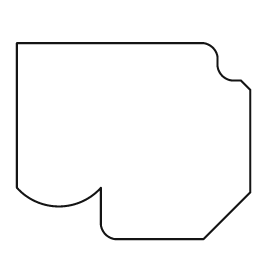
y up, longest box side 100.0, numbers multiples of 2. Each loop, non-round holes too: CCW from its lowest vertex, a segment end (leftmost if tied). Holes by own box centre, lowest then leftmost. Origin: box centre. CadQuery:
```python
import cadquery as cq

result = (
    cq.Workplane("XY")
    .moveTo(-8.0, -42.0)
    .lineTo(30.0, -42.0)
    .lineTo(50.0, -22.0)
    .lineTo(50.0, 22.0)
    .lineTo(46.0, 26.0)
    .lineTo(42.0, 26.0)
    .threePointArc((38.0, 28.0), (36.0, 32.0))
    .lineTo(36.0, 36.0)
    .threePointArc((34.0, 40.0), (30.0, 42.0))
    .lineTo(-50.0, 42.0)
    .lineTo(-50.0, -20.0)
    .threePointArc((-32.0, -28.0), (-14.0, -20.0))
    .lineTo(-14.0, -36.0)
    .threePointArc((-12.0, -40.0), (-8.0, -42.0))
    .close()
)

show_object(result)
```